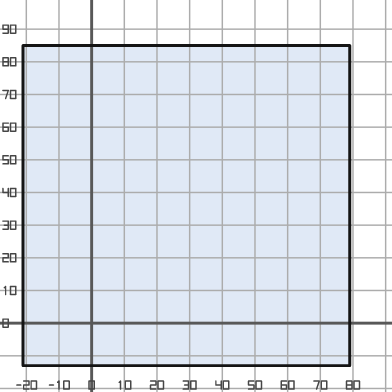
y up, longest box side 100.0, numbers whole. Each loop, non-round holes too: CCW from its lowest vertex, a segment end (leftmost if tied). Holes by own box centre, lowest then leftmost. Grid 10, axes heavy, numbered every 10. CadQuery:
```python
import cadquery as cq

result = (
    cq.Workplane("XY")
    .moveTo(-21.0, -13.0)
    .lineTo(79.0, -13.0)
    .lineTo(79.0, 85.0)
    .lineTo(-21.0, 85.0)
    .close()
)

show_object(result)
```